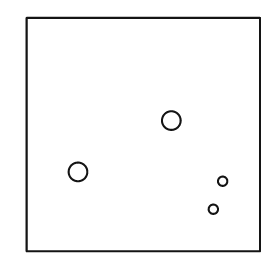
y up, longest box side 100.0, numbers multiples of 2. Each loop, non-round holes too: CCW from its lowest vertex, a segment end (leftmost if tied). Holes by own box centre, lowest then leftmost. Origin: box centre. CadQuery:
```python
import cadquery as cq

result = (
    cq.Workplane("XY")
    .moveTo(-50.0, -50.0)
    .lineTo(50.0, -50.0)
    .lineTo(50.0, 50.0)
    .lineTo(-50.0, 50.0)
    .close()
    .moveTo(30.0, -32.0)
    .circle(2.0)
    .moveTo(34.0, -20.0)
    .circle(2.0)
    .moveTo(-28.0, -16.0)
    .circle(4.0)
    .moveTo(12.0, 6.0)
    .circle(4.0)
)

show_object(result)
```